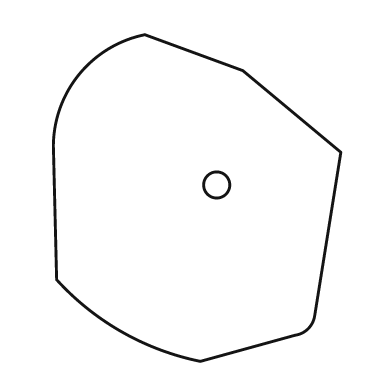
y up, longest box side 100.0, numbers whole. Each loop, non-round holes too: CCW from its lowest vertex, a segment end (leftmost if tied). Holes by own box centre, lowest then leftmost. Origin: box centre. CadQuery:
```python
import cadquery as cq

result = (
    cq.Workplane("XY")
    .moveTo(1.0, -50.0)
    .lineTo(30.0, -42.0)
    .threePointArc((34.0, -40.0), (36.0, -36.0))
    .lineTo(44.0, 14.0)
    .lineTo(14.0, 39.0)
    .lineTo(-16.0, 50.0)
    .threePointArc((-36.0, 38.0), (-44.0, 16.0))
    .lineTo(-43.0, -25.0)
    .threePointArc((-23.0, -41.0), (1.0, -50.0))
    .close()
    .moveTo(6.0, 4.0)
    .circle(4.0)
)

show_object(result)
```